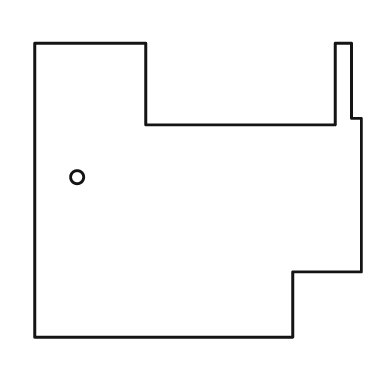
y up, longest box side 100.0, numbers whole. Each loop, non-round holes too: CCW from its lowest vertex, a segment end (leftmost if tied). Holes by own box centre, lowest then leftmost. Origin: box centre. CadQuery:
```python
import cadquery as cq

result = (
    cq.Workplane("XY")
    .moveTo(-50.0, -45.0)
    .lineTo(29.0, -45.0)
    .lineTo(29.0, -25.0)
    .lineTo(50.0, -25.0)
    .lineTo(50.0, 22.0)
    .lineTo(47.0, 22.0)
    .lineTo(47.0, 45.0)
    .lineTo(42.0, 45.0)
    .lineTo(42.0, 20.0)
    .lineTo(-16.0, 20.0)
    .lineTo(-16.0, 45.0)
    .lineTo(-50.0, 45.0)
    .close()
    .moveTo(-37.0, 4.0)
    .circle(2.0)
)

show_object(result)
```